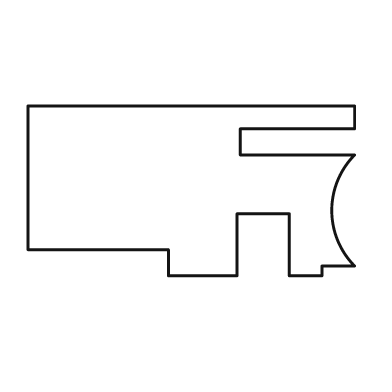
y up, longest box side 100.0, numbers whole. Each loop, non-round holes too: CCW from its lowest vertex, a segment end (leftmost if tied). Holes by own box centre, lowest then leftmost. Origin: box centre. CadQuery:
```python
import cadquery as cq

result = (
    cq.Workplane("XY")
    .moveTo(-7.0, -26.0)
    .lineTo(14.0, -26.0)
    .lineTo(14.0, -7.0)
    .lineTo(30.0, -7.0)
    .lineTo(30.0, -26.0)
    .lineTo(40.0, -26.0)
    .lineTo(40.0, -23.0)
    .lineTo(50.0, -23.0)
    .threePointArc((43.0, -6.0), (50.0, 11.0))
    .lineTo(15.0, 11.0)
    .lineTo(15.0, 19.0)
    .lineTo(50.0, 19.0)
    .lineTo(50.0, 26.0)
    .lineTo(-50.0, 26.0)
    .lineTo(-50.0, -18.0)
    .lineTo(-7.0, -18.0)
    .close()
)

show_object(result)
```